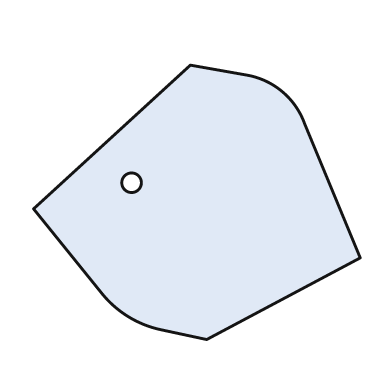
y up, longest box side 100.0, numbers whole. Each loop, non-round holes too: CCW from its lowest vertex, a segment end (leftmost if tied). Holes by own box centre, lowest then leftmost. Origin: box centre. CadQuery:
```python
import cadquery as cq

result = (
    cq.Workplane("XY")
    .moveTo(3.0, -42.0)
    .lineTo(50.0, -17.0)
    .lineTo(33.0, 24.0)
    .threePointArc((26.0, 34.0), (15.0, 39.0))
    .lineTo(-2.0, 42.0)
    .lineTo(-50.0, -2.0)
    .lineTo(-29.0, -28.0)
    .threePointArc((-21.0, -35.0), (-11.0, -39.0))
    .close()
    .moveTo(-20.0, 6.0)
    .circle(3.0)
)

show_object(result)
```